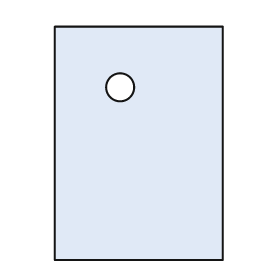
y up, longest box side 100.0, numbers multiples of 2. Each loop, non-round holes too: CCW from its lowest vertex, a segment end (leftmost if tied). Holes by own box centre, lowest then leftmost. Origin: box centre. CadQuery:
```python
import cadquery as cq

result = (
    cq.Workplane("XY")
    .moveTo(-36.0, -50.0)
    .lineTo(36.0, -50.0)
    .lineTo(36.0, 50.0)
    .lineTo(-36.0, 50.0)
    .close()
    .moveTo(-8.0, 24.0)
    .circle(6.0)
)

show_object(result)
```